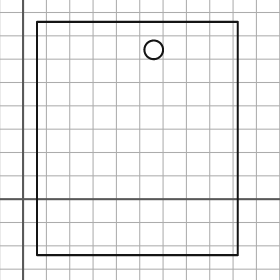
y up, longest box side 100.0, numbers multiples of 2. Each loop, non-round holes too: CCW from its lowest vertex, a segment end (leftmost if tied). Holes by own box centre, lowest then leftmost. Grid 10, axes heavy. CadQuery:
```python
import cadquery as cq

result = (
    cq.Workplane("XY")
    .moveTo(6.0, -24.0)
    .lineTo(92.0, -24.0)
    .lineTo(92.0, 76.0)
    .lineTo(6.0, 76.0)
    .close()
    .moveTo(56.0, 64.0)
    .circle(4.0)
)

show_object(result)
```